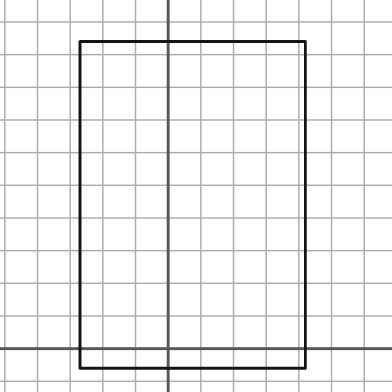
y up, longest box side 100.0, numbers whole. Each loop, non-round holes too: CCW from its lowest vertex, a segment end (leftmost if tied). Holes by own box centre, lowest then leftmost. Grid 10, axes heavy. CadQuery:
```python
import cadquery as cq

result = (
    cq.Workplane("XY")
    .moveTo(-27.0, -6.0)
    .lineTo(42.0, -6.0)
    .lineTo(42.0, 94.0)
    .lineTo(-27.0, 94.0)
    .close()
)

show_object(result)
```